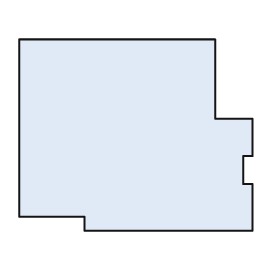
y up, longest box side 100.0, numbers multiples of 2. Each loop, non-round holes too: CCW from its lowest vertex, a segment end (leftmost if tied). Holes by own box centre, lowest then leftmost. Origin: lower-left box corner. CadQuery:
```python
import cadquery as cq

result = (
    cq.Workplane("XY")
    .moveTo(28.0, 0.0)
    .lineTo(100.0, 0.0)
    .lineTo(100.0, 20.0)
    .lineTo(96.0, 20.0)
    .lineTo(96.0, 32.0)
    .lineTo(100.0, 32.0)
    .lineTo(100.0, 48.0)
    .lineTo(84.0, 48.0)
    .lineTo(84.0, 82.0)
    .lineTo(0.0, 82.0)
    .lineTo(0.0, 6.0)
    .lineTo(28.0, 6.0)
    .close()
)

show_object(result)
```